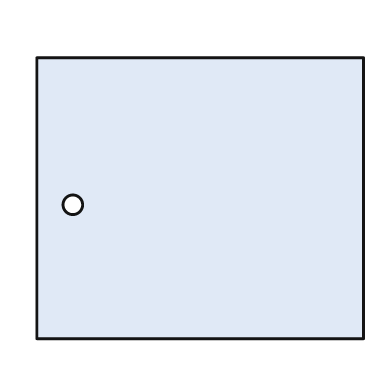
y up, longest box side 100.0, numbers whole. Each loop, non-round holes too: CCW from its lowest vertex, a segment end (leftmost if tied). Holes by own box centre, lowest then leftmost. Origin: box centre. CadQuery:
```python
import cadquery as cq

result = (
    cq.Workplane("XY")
    .moveTo(-50.0, -43.0)
    .lineTo(50.0, -43.0)
    .lineTo(50.0, 43.0)
    .lineTo(-50.0, 43.0)
    .close()
    .moveTo(-39.0, -2.0)
    .circle(3.0)
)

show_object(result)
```